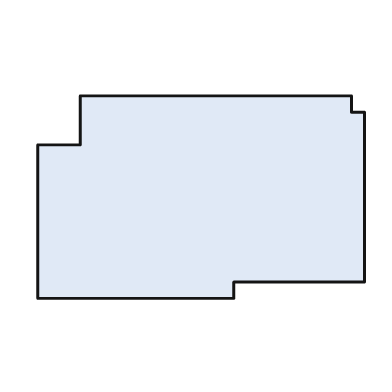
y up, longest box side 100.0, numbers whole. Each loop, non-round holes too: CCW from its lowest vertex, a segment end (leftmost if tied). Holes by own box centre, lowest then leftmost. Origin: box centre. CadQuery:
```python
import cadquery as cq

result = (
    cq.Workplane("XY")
    .moveTo(-50.0, -31.0)
    .lineTo(10.0, -31.0)
    .lineTo(10.0, -26.0)
    .lineTo(50.0, -26.0)
    .lineTo(50.0, 26.0)
    .lineTo(46.0, 26.0)
    .lineTo(46.0, 31.0)
    .lineTo(-37.0, 31.0)
    .lineTo(-37.0, 16.0)
    .lineTo(-50.0, 16.0)
    .close()
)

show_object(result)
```